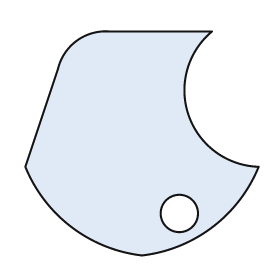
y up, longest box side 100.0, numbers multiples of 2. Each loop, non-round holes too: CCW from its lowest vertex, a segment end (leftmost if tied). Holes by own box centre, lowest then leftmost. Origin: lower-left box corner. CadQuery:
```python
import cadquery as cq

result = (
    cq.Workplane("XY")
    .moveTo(50.0, 0.0)
    .threePointArc((80.0, 12.0), (100.0, 38.0))
    .threePointArc((70.0, 60.0), (80.0, 96.0))
    .lineTo(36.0, 96.0)
    .threePointArc((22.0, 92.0), (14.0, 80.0))
    .lineTo(0.0, 38.0)
    .threePointArc((20.0, 12.0), (50.0, 0.0))
    .close()
    .moveTo(66.0, 18.0)
    .circle(8.0)
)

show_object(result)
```